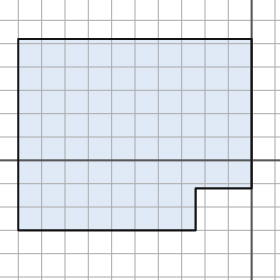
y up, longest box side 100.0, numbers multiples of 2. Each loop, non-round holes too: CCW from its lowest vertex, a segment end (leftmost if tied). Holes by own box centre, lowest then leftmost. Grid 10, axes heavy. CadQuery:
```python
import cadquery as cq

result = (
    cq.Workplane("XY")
    .moveTo(-100.0, -30.0)
    .lineTo(-24.0, -30.0)
    .lineTo(-24.0, -12.0)
    .lineTo(0.0, -12.0)
    .lineTo(0.0, 52.0)
    .lineTo(-100.0, 52.0)
    .close()
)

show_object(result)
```